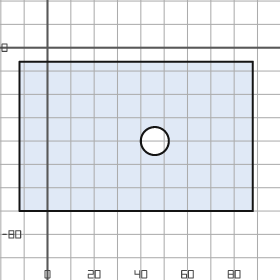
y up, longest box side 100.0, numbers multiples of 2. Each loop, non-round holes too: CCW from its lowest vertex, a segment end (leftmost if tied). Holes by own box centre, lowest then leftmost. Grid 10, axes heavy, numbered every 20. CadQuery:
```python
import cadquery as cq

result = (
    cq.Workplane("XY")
    .moveTo(-12.0, -70.0)
    .lineTo(88.0, -70.0)
    .lineTo(88.0, -6.0)
    .lineTo(-12.0, -6.0)
    .close()
    .moveTo(46.0, -40.0)
    .circle(6.0)
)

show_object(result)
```